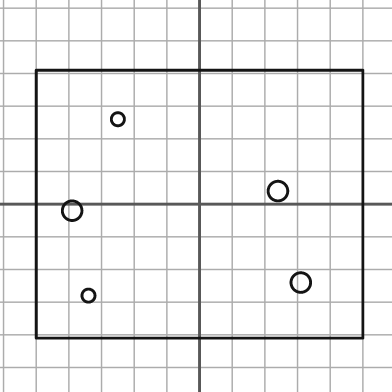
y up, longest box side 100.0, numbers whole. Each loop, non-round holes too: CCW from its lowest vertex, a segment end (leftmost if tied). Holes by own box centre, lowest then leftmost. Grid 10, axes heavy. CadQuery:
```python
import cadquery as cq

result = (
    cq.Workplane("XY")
    .moveTo(-50.0, -41.0)
    .lineTo(50.0, -41.0)
    .lineTo(50.0, 41.0)
    .lineTo(-50.0, 41.0)
    .close()
    .moveTo(-34.0, -28.0)
    .circle(2.0)
    .moveTo(31.0, -24.0)
    .circle(3.0)
    .moveTo(-39.0, -2.0)
    .circle(3.0)
    .moveTo(24.0, 4.0)
    .circle(3.0)
    .moveTo(-25.0, 26.0)
    .circle(2.0)
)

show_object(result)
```